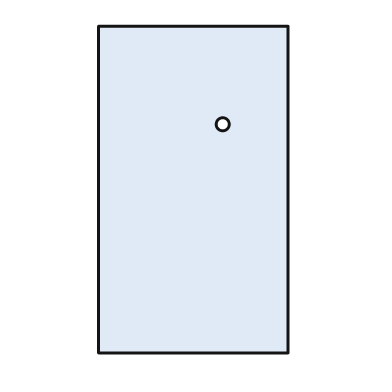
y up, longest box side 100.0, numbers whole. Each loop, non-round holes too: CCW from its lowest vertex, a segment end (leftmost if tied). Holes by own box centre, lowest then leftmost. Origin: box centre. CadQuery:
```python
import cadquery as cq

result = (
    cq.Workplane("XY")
    .moveTo(-29.0, -50.0)
    .lineTo(29.0, -50.0)
    .lineTo(29.0, 50.0)
    .lineTo(-29.0, 50.0)
    .close()
    .moveTo(9.0, 20.0)
    .circle(2.0)
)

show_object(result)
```